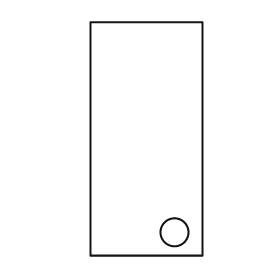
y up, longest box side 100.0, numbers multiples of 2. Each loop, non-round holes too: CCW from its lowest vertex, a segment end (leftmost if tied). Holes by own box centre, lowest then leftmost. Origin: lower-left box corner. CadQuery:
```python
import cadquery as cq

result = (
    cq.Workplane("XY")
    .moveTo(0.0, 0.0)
    .lineTo(48.0, 0.0)
    .lineTo(48.0, 100.0)
    .lineTo(0.0, 100.0)
    .close()
    .moveTo(36.0, 10.0)
    .circle(6.0)
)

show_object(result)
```